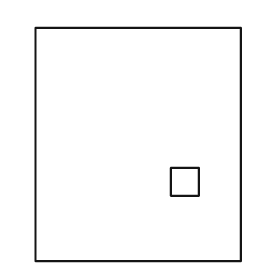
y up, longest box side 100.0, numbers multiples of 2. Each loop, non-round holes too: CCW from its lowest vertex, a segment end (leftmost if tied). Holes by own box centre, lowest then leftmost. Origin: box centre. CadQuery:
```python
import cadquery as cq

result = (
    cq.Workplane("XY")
    .moveTo(-44.0, -50.0)
    .lineTo(44.0, -50.0)
    .lineTo(44.0, 50.0)
    .lineTo(-44.0, 50.0)
    .close()
    .moveTo(14.0, -22.0)
    .lineTo(26.0, -22.0)
    .lineTo(26.0, -10.0)
    .lineTo(14.0, -10.0)
    .close()
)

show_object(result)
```